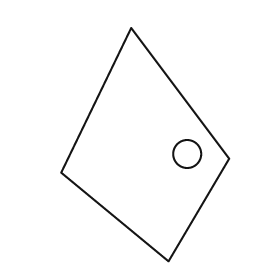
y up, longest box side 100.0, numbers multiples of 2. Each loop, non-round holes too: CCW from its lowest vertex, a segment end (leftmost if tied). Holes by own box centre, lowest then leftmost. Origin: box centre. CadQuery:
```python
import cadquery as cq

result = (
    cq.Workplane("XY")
    .moveTo(10.0, -50.0)
    .lineTo(36.0, -6.0)
    .lineTo(-6.0, 50.0)
    .lineTo(-36.0, -12.0)
    .close()
    .moveTo(18.0, -4.0)
    .circle(6.0)
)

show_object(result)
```